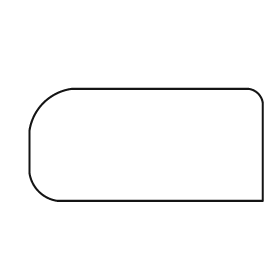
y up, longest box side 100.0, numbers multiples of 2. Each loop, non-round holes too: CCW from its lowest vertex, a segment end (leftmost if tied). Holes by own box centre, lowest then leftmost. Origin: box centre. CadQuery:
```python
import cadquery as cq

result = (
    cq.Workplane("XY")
    .moveTo(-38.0, -24.0)
    .lineTo(50.0, -24.0)
    .lineTo(50.0, 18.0)
    .threePointArc((48.0, 22.0), (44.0, 24.0))
    .lineTo(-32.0, 24.0)
    .threePointArc((-44.0, 18.0), (-50.0, 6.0))
    .lineTo(-50.0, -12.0)
    .threePointArc((-46.0, -20.0), (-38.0, -24.0))
    .close()
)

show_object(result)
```